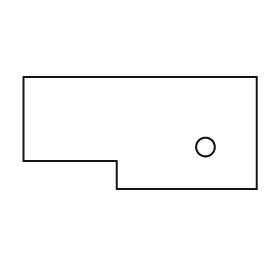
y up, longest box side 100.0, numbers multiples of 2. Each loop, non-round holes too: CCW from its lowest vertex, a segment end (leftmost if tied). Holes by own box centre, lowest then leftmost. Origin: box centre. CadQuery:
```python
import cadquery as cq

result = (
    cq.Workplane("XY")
    .moveTo(-10.0, -24.0)
    .lineTo(50.0, -24.0)
    .lineTo(50.0, 24.0)
    .lineTo(-50.0, 24.0)
    .lineTo(-50.0, -12.0)
    .lineTo(-10.0, -12.0)
    .close()
    .moveTo(28.0, -6.0)
    .circle(4.0)
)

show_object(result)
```